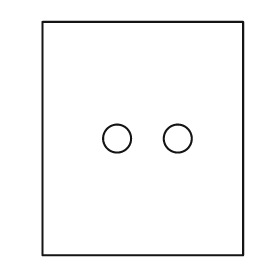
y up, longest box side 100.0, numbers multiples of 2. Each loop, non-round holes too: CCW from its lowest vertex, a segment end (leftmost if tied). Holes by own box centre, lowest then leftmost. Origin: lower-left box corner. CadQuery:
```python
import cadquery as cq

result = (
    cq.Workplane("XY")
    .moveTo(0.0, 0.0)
    .lineTo(86.0, 0.0)
    .lineTo(86.0, 100.0)
    .lineTo(0.0, 100.0)
    .close()
    .moveTo(32.0, 50.0)
    .circle(6.0)
    .moveTo(58.0, 50.0)
    .circle(6.0)
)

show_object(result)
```